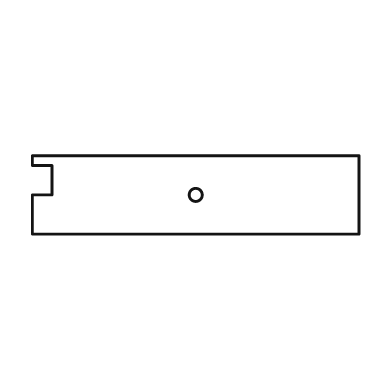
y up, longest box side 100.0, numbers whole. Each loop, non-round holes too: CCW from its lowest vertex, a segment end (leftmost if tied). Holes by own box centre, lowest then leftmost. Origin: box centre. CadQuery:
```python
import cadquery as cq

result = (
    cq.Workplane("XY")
    .moveTo(-50.0, -12.0)
    .lineTo(50.0, -12.0)
    .lineTo(50.0, 12.0)
    .lineTo(-50.0, 12.0)
    .lineTo(-50.0, 9.0)
    .lineTo(-44.0, 9.0)
    .lineTo(-44.0, 0.0)
    .lineTo(-50.0, 0.0)
    .close()
    .moveTo(0.0, 0.0)
    .circle(2.0)
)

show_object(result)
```